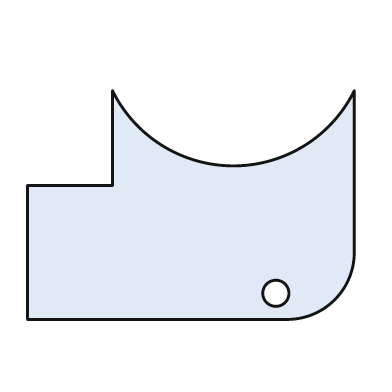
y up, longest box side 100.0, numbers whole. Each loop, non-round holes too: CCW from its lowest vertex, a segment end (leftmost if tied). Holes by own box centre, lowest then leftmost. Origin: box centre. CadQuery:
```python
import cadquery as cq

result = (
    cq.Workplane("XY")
    .moveTo(-50.0, -35.0)
    .lineTo(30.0, -35.0)
    .threePointArc((44.0, -29.0), (50.0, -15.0))
    .lineTo(50.0, 35.0)
    .threePointArc((13.0, 12.0), (-24.0, 35.0))
    .lineTo(-24.0, 6.0)
    .lineTo(-50.0, 6.0)
    .close()
    .moveTo(26.0, -27.0)
    .circle(4.0)
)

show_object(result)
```